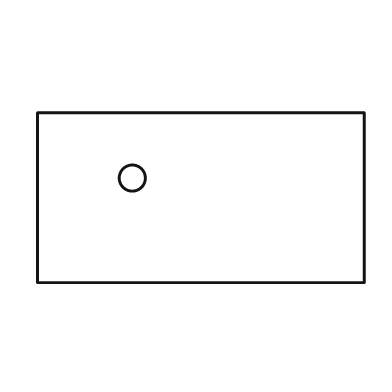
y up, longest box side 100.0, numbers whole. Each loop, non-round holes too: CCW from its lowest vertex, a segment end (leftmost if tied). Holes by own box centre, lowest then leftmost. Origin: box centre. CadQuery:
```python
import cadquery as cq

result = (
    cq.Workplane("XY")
    .moveTo(-50.0, -26.0)
    .lineTo(50.0, -26.0)
    .lineTo(50.0, 26.0)
    .lineTo(-50.0, 26.0)
    .close()
    .moveTo(-21.0, 6.0)
    .circle(4.0)
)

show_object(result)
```